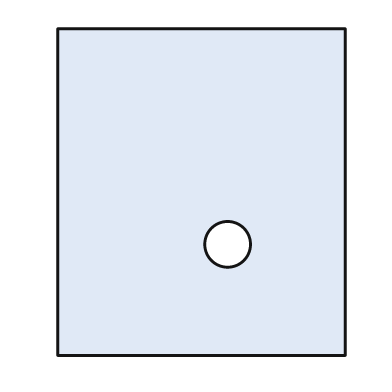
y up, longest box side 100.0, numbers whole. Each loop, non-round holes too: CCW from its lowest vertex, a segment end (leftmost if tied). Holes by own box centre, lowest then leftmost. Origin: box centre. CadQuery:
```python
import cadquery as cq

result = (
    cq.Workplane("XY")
    .moveTo(-44.0, -50.0)
    .lineTo(44.0, -50.0)
    .lineTo(44.0, 50.0)
    .lineTo(-44.0, 50.0)
    .close()
    .moveTo(8.0, -16.0)
    .circle(7.0)
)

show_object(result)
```